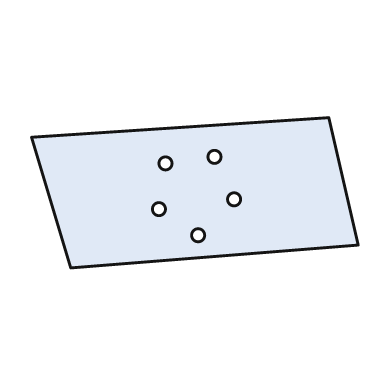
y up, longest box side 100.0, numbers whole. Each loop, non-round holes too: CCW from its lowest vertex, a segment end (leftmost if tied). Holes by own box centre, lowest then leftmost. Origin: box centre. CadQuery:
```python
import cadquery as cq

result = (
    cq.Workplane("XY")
    .moveTo(-38.0, -23.0)
    .lineTo(50.0, -16.0)
    .lineTo(41.0, 23.0)
    .lineTo(-50.0, 17.0)
    .close()
    .moveTo(1.0, -13.0)
    .circle(2.0)
    .moveTo(-11.0, -5.0)
    .circle(2.0)
    .moveTo(12.0, -2.0)
    .circle(2.0)
    .moveTo(-9.0, 9.0)
    .circle(2.0)
    .moveTo(6.0, 11.0)
    .circle(2.0)
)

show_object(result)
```